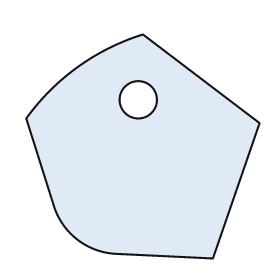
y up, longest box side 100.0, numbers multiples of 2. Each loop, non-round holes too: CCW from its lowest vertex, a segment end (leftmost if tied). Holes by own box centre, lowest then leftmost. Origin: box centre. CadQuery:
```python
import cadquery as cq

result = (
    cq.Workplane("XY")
    .moveTo(30.0, -48.0)
    .lineTo(50.0, 10.0)
    .lineTo(0.0, 48.0)
    .threePointArc((-28.0, 34.0), (-50.0, 12.0))
    .lineTo(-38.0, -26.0)
    .threePointArc((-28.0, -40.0), (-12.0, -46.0))
    .close()
    .moveTo(-2.0, 20.0)
    .circle(8.0)
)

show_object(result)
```